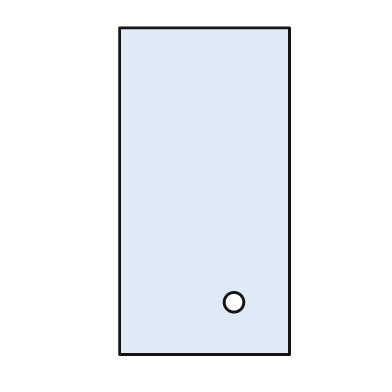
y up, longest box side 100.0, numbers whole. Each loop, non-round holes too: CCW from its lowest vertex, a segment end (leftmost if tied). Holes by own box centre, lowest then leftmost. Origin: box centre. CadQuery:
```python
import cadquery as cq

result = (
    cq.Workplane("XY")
    .moveTo(-26.0, -50.0)
    .lineTo(26.0, -50.0)
    .lineTo(26.0, 50.0)
    .lineTo(-26.0, 50.0)
    .close()
    .moveTo(9.0, -34.0)
    .circle(3.0)
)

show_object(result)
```